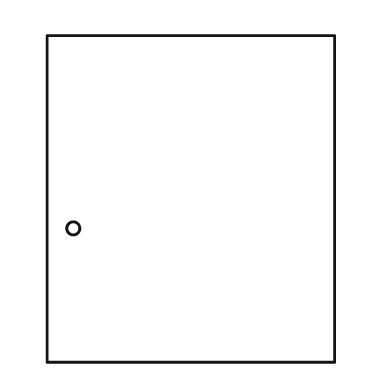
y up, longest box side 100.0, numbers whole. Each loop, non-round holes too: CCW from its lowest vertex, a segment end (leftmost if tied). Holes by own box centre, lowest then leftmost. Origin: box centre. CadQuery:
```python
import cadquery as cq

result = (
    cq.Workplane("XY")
    .moveTo(-44.0, -50.0)
    .lineTo(44.0, -50.0)
    .lineTo(44.0, 50.0)
    .lineTo(-44.0, 50.0)
    .close()
    .moveTo(-36.0, -9.0)
    .circle(2.0)
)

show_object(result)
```